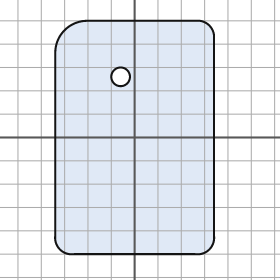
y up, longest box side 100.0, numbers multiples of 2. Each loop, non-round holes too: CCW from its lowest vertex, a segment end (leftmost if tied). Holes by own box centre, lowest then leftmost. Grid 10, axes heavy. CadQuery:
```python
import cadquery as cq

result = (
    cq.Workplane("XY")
    .moveTo(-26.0, -50.0)
    .lineTo(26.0, -50.0)
    .threePointArc((32.0, -48.0), (34.0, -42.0))
    .lineTo(34.0, 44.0)
    .threePointArc((32.0, 48.0), (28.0, 50.0))
    .lineTo(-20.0, 50.0)
    .threePointArc((-30.0, 46.0), (-34.0, 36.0))
    .lineTo(-34.0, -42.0)
    .threePointArc((-32.0, -48.0), (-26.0, -50.0))
    .close()
    .moveTo(-6.0, 26.0)
    .circle(4.0)
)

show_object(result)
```